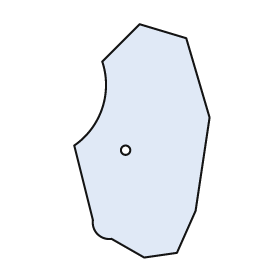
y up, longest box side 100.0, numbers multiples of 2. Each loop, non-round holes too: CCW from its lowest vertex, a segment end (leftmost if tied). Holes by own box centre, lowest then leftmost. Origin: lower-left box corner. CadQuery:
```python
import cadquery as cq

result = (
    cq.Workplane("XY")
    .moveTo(30.0, 0.0)
    .lineTo(44.0, 2.0)
    .lineTo(52.0, 20.0)
    .lineTo(58.0, 60.0)
    .lineTo(48.0, 94.0)
    .lineTo(28.0, 100.0)
    .lineTo(12.0, 84.0)
    .threePointArc((12.0, 64.0), (0.0, 48.0))
    .lineTo(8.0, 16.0)
    .threePointArc((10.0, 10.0), (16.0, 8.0))
    .close()
    .moveTo(22.0, 46.0)
    .circle(2.0)
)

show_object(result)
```